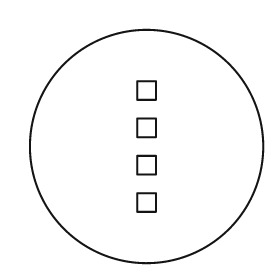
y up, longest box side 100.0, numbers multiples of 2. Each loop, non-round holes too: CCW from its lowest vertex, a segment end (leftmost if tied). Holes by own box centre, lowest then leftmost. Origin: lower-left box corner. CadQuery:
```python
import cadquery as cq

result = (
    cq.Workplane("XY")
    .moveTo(50.0, 50.0)
    .circle(50.0)
    .moveTo(46.0, 22.0)
    .lineTo(54.0, 22.0)
    .lineTo(54.0, 30.0)
    .lineTo(46.0, 30.0)
    .close()
    .moveTo(46.0, 38.0)
    .lineTo(54.0, 38.0)
    .lineTo(54.0, 46.0)
    .lineTo(46.0, 46.0)
    .close()
    .moveTo(46.0, 54.0)
    .lineTo(54.0, 54.0)
    .lineTo(54.0, 62.0)
    .lineTo(46.0, 62.0)
    .close()
    .moveTo(46.0, 70.0)
    .lineTo(54.0, 70.0)
    .lineTo(54.0, 78.0)
    .lineTo(46.0, 78.0)
    .close()
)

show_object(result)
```